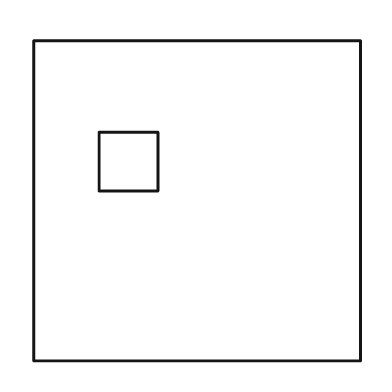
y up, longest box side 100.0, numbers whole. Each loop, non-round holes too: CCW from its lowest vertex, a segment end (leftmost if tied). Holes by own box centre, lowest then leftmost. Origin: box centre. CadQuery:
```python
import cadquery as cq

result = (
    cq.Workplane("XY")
    .moveTo(-50.0, -49.0)
    .lineTo(50.0, -49.0)
    .lineTo(50.0, 49.0)
    .lineTo(-50.0, 49.0)
    .close()
    .moveTo(-30.0, 3.0)
    .lineTo(-12.0, 3.0)
    .lineTo(-12.0, 21.0)
    .lineTo(-30.0, 21.0)
    .close()
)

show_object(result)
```